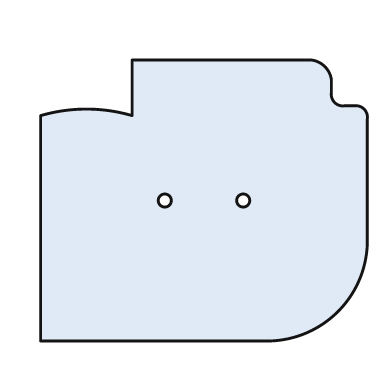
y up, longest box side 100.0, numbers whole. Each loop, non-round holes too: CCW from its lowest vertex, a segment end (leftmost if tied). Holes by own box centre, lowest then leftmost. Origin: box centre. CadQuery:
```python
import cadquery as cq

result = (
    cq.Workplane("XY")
    .moveTo(-50.0, -43.0)
    .lineTo(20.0, -43.0)
    .threePointArc((41.0, -34.0), (50.0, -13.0))
    .lineTo(50.0, 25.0)
    .threePointArc((49.0, 28.0), (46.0, 29.0))
    .lineTo(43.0, 29.0)
    .threePointArc((40.0, 30.0), (39.0, 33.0))
    .lineTo(39.0, 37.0)
    .threePointArc((37.0, 41.0), (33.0, 43.0))
    .lineTo(-22.0, 43.0)
    .lineTo(-22.0, 26.0)
    .threePointArc((-36.0, 28.0), (-50.0, 26.0))
    .close()
    .moveTo(-12.0, 0.0)
    .circle(2.0)
    .moveTo(12.0, 0.0)
    .circle(2.0)
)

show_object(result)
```